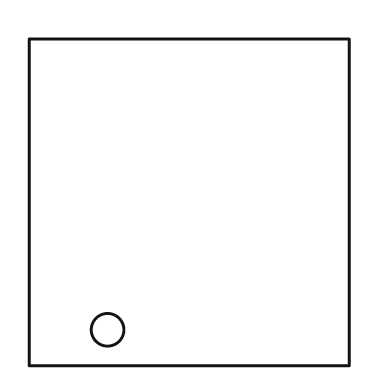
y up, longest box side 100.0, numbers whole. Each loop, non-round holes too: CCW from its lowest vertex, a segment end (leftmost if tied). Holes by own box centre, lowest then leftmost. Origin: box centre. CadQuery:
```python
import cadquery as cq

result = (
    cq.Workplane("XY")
    .moveTo(-49.0, -50.0)
    .lineTo(49.0, -50.0)
    .lineTo(49.0, 50.0)
    .lineTo(-49.0, 50.0)
    .close()
    .moveTo(-25.0, -39.0)
    .circle(5.0)
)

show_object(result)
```